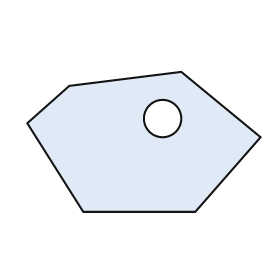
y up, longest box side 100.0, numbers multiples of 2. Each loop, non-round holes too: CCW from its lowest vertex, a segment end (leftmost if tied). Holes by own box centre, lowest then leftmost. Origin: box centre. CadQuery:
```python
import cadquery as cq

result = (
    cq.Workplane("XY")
    .moveTo(-26.0, -30.0)
    .lineTo(22.0, -30.0)
    .lineTo(50.0, 2.0)
    .lineTo(16.0, 30.0)
    .lineTo(-32.0, 24.0)
    .lineTo(-50.0, 8.0)
    .close()
    .moveTo(8.0, 10.0)
    .circle(8.0)
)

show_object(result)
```